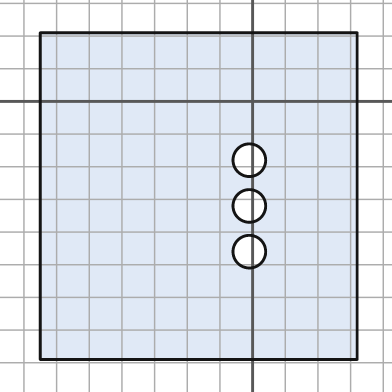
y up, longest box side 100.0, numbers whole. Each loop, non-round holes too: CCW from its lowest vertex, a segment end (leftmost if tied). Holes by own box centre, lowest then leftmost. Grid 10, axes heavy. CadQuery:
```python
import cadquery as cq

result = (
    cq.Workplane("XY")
    .moveTo(-65.0, -79.0)
    .lineTo(32.0, -79.0)
    .lineTo(32.0, 21.0)
    .lineTo(-65.0, 21.0)
    .close()
    .moveTo(-1.0, -46.0)
    .circle(5.0)
    .moveTo(-1.0, -32.0)
    .circle(5.0)
    .moveTo(-1.0, -18.0)
    .circle(5.0)
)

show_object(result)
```